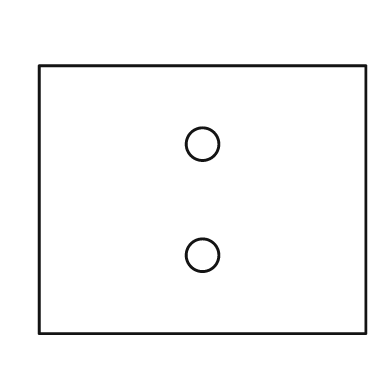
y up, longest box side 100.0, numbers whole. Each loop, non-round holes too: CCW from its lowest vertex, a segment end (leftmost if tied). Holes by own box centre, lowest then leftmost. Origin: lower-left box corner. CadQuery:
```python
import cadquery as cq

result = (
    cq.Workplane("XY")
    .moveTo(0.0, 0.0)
    .lineTo(100.0, 0.0)
    .lineTo(100.0, 82.0)
    .lineTo(0.0, 82.0)
    .close()
    .moveTo(50.0, 24.0)
    .circle(5.0)
    .moveTo(50.0, 58.0)
    .circle(5.0)
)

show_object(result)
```